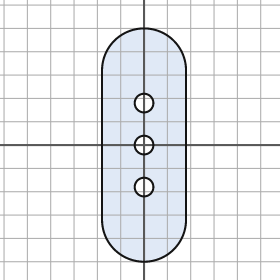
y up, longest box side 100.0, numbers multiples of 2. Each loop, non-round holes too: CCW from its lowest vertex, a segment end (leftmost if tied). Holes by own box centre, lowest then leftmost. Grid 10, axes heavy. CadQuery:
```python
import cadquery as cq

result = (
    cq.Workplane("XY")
    .moveTo(-18.0, -32.0)
    .threePointArc((0.0, -50.0), (18.0, -32.0))
    .lineTo(18.0, 32.0)
    .threePointArc((0.0, 50.0), (-18.0, 32.0))
    .close()
    .moveTo(0.0, -18.0)
    .circle(4.0)
    .moveTo(0.0, 0.0)
    .circle(4.0)
    .moveTo(0.0, 18.0)
    .circle(4.0)
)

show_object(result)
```